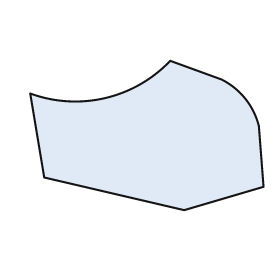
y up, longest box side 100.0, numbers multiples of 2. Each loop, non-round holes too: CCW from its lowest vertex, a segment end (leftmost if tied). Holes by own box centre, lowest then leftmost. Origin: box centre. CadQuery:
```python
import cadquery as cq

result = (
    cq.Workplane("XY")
    .moveTo(16.0, -32.0)
    .lineTo(50.0, -22.0)
    .lineTo(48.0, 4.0)
    .threePointArc((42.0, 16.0), (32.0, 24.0))
    .lineTo(10.0, 32.0)
    .threePointArc((-18.0, 16.0), (-50.0, 18.0))
    .lineTo(-44.0, -18.0)
    .close()
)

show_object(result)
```